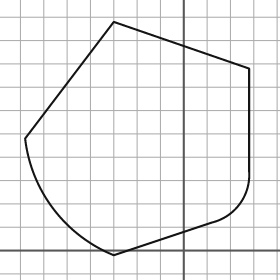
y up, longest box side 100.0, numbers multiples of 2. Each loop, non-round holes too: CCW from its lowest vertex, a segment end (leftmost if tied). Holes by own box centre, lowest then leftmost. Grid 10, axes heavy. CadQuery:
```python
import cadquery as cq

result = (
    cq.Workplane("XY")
    .moveTo(-30.0, -2.0)
    .lineTo(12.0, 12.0)
    .threePointArc((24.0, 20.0), (28.0, 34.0))
    .lineTo(28.0, 78.0)
    .lineTo(-30.0, 98.0)
    .lineTo(-68.0, 48.0)
    .threePointArc((-56.0, 18.0), (-30.0, -2.0))
    .close()
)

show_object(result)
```